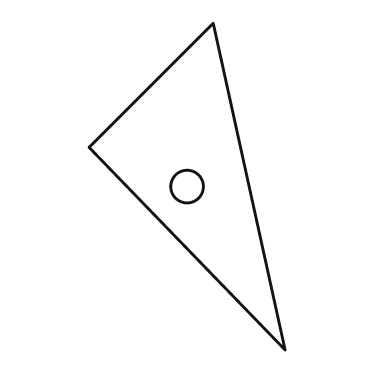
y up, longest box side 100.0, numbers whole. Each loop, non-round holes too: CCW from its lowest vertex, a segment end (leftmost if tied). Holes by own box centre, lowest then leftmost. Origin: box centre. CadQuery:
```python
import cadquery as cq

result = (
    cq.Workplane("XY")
    .moveTo(30.0, -50.0)
    .lineTo(8.0, 50.0)
    .lineTo(-30.0, 12.0)
    .close()
    .moveTo(0.0, 0.0)
    .circle(5.0)
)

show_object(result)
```